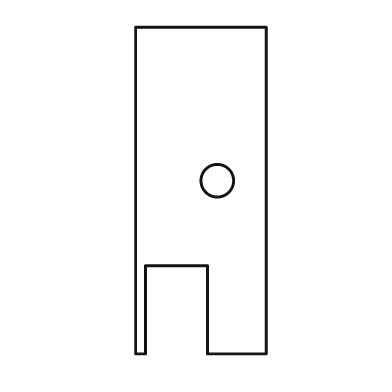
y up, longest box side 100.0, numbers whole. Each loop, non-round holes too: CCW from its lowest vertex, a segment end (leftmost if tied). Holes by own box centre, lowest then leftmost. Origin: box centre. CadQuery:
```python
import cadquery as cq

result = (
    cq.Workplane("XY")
    .moveTo(-20.0, -50.0)
    .lineTo(-17.0, -50.0)
    .lineTo(-17.0, -23.0)
    .lineTo(2.0, -23.0)
    .lineTo(2.0, -50.0)
    .lineTo(20.0, -50.0)
    .lineTo(20.0, 50.0)
    .lineTo(-20.0, 50.0)
    .close()
    .moveTo(5.0, 3.0)
    .circle(5.0)
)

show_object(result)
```